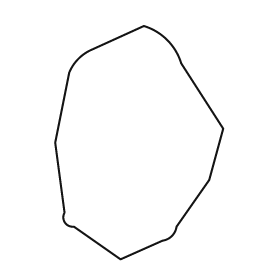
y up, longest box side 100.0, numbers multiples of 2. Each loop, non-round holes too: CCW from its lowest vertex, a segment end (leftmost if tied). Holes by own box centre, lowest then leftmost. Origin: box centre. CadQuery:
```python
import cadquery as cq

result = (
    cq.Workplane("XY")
    .moveTo(-8.0, -50.0)
    .lineTo(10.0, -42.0)
    .threePointArc((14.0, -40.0), (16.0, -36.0))
    .lineTo(30.0, -16.0)
    .lineTo(36.0, 6.0)
    .lineTo(18.0, 34.0)
    .threePointArc((12.0, 44.0), (2.0, 50.0))
    .lineTo(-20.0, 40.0)
    .threePointArc((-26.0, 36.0), (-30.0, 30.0))
    .lineTo(-36.0, 0.0)
    .lineTo(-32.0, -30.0)
    .threePointArc((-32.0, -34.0), (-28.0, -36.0))
    .close()
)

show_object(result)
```